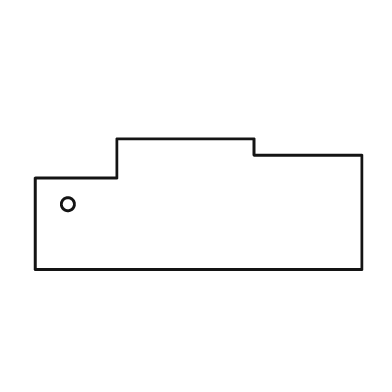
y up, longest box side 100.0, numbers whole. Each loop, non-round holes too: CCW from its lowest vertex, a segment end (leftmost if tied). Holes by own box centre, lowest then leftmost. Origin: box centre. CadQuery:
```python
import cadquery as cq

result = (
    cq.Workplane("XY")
    .moveTo(-50.0, -20.0)
    .lineTo(50.0, -20.0)
    .lineTo(50.0, 15.0)
    .lineTo(17.0, 15.0)
    .lineTo(17.0, 20.0)
    .lineTo(-25.0, 20.0)
    .lineTo(-25.0, 8.0)
    .lineTo(-50.0, 8.0)
    .close()
    .moveTo(-40.0, 0.0)
    .circle(2.0)
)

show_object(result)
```